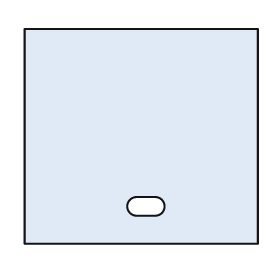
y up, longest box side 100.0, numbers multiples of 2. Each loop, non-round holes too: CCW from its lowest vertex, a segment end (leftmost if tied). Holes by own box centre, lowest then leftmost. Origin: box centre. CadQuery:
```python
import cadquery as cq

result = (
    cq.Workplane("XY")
    .moveTo(-50.0, -46.0)
    .lineTo(50.0, -46.0)
    .lineTo(50.0, 46.0)
    .lineTo(-50.0, 46.0)
    .close()
    .moveTo(-2.0, -34.0)
    .lineTo(6.0, -34.0)
    .threePointArc((10.0, -30.0), (6.0, -26.0))
    .lineTo(-2.0, -26.0)
    .threePointArc((-6.0, -30.0), (-2.0, -34.0))
    .close()
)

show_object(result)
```